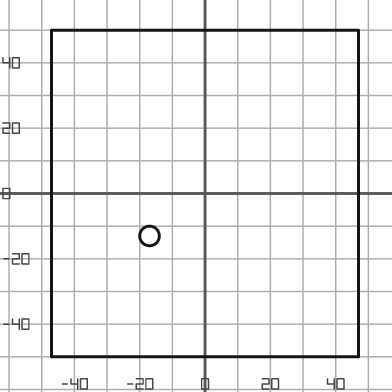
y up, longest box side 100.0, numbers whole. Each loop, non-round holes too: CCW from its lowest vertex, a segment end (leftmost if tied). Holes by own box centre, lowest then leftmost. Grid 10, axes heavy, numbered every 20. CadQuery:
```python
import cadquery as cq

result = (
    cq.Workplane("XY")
    .moveTo(-47.0, -50.0)
    .lineTo(47.0, -50.0)
    .lineTo(47.0, 50.0)
    .lineTo(-47.0, 50.0)
    .close()
    .moveTo(-17.0, -13.0)
    .circle(3.0)
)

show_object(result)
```